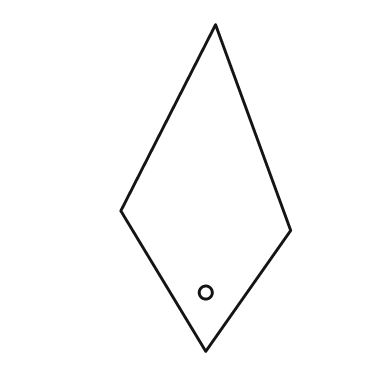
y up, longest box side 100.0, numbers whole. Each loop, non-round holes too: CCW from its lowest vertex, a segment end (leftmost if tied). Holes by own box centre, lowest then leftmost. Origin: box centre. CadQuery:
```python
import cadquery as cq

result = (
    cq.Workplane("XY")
    .moveTo(0.0, -50.0)
    .lineTo(26.0, -13.0)
    .lineTo(3.0, 50.0)
    .lineTo(-26.0, -7.0)
    .close()
    .moveTo(0.0, -32.0)
    .circle(2.0)
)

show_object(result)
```